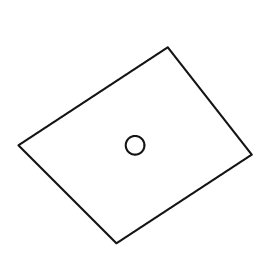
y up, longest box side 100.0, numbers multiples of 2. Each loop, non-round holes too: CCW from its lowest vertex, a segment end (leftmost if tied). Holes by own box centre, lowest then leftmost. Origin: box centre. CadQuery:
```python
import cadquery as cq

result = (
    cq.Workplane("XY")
    .moveTo(-8.0, -42.0)
    .lineTo(50.0, -4.0)
    .lineTo(14.0, 42.0)
    .lineTo(-50.0, 0.0)
    .close()
    .moveTo(0.0, 0.0)
    .circle(4.0)
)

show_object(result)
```